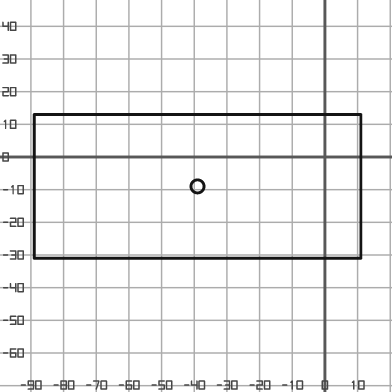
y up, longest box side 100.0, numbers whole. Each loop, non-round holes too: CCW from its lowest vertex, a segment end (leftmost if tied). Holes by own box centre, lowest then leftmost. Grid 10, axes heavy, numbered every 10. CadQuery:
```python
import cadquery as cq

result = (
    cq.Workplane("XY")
    .moveTo(-89.0, -31.0)
    .lineTo(11.0, -31.0)
    .lineTo(11.0, 13.0)
    .lineTo(-89.0, 13.0)
    .close()
    .moveTo(-39.0, -9.0)
    .circle(2.0)
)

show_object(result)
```